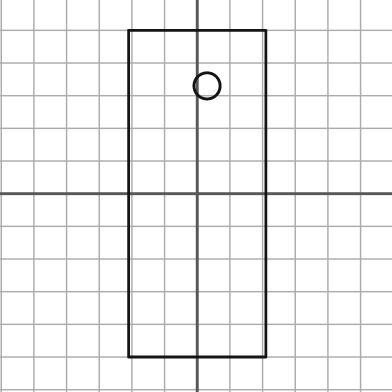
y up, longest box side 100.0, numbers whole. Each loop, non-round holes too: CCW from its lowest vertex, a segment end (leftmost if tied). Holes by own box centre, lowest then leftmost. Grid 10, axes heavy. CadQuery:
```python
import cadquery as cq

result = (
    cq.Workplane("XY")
    .moveTo(-21.0, -50.0)
    .lineTo(21.0, -50.0)
    .lineTo(21.0, 50.0)
    .lineTo(-21.0, 50.0)
    .close()
    .moveTo(3.0, 33.0)
    .circle(4.0)
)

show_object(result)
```